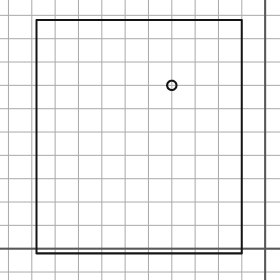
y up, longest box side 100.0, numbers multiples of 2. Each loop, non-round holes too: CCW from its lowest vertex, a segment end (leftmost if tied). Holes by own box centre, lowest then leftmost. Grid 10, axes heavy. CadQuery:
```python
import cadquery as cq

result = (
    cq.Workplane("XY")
    .moveTo(-98.0, -2.0)
    .lineTo(-10.0, -2.0)
    .lineTo(-10.0, 98.0)
    .lineTo(-98.0, 98.0)
    .close()
    .moveTo(-40.0, 70.0)
    .circle(2.0)
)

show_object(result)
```